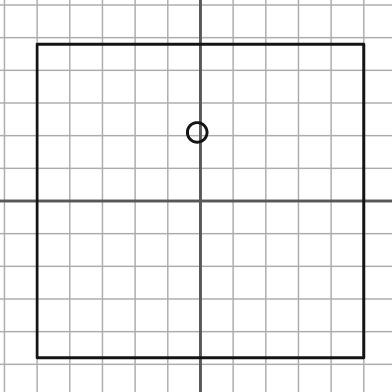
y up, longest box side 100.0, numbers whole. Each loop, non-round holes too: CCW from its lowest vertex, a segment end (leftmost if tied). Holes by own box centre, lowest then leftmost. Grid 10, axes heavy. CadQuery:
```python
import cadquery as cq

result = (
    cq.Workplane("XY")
    .moveTo(-50.0, -48.0)
    .lineTo(50.0, -48.0)
    .lineTo(50.0, 48.0)
    .lineTo(-50.0, 48.0)
    .close()
    .moveTo(-1.0, 21.0)
    .circle(3.0)
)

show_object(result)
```